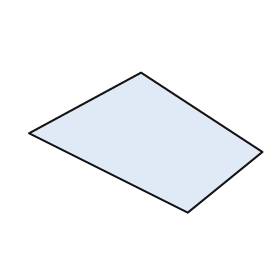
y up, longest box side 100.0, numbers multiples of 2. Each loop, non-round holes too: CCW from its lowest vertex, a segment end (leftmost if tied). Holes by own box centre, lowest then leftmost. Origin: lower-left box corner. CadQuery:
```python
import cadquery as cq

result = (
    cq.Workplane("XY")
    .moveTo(68.0, 0.0)
    .lineTo(100.0, 26.0)
    .lineTo(48.0, 60.0)
    .lineTo(0.0, 34.0)
    .close()
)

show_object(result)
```